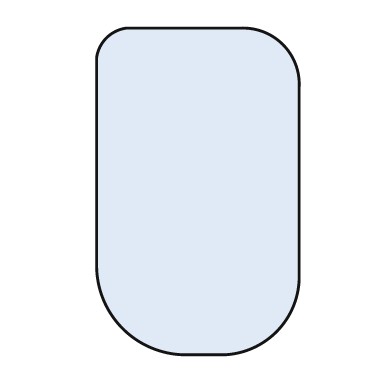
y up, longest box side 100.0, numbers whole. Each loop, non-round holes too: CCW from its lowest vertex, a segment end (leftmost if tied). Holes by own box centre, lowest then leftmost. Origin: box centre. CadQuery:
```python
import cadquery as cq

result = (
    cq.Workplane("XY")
    .moveTo(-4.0, -50.0)
    .lineTo(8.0, -50.0)
    .threePointArc((24.0, -43.0), (31.0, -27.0))
    .lineTo(31.0, 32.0)
    .threePointArc((26.0, 45.0), (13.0, 50.0))
    .lineTo(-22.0, 50.0)
    .threePointArc((-28.0, 47.0), (-31.0, 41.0))
    .lineTo(-31.0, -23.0)
    .threePointArc((-23.0, -42.0), (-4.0, -50.0))
    .close()
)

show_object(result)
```